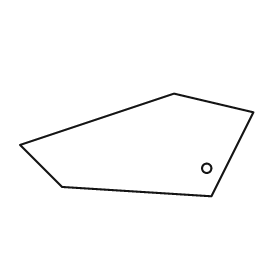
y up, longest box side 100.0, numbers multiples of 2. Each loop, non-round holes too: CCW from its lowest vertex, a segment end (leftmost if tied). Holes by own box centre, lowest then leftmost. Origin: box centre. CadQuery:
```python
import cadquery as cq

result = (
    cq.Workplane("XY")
    .moveTo(32.0, -22.0)
    .lineTo(50.0, 14.0)
    .lineTo(16.0, 22.0)
    .lineTo(-50.0, 0.0)
    .lineTo(-32.0, -18.0)
    .close()
    .moveTo(30.0, -10.0)
    .circle(2.0)
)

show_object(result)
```